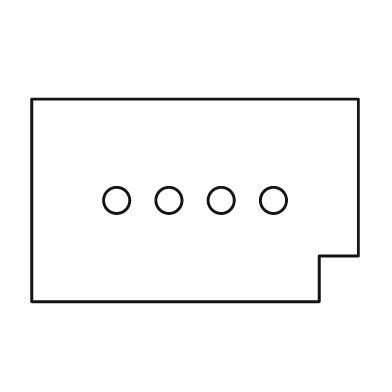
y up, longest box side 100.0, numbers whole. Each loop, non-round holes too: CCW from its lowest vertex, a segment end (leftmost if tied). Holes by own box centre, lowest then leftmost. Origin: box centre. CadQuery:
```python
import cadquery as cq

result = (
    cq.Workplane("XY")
    .moveTo(-50.0, -31.0)
    .lineTo(38.0, -31.0)
    .lineTo(38.0, -17.0)
    .lineTo(50.0, -17.0)
    .lineTo(50.0, 31.0)
    .lineTo(-50.0, 31.0)
    .close()
    .moveTo(-24.0, 0.0)
    .circle(4.0)
    .moveTo(-8.0, 0.0)
    .circle(4.0)
    .moveTo(8.0, 0.0)
    .circle(4.0)
    .moveTo(24.0, 0.0)
    .circle(4.0)
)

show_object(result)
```